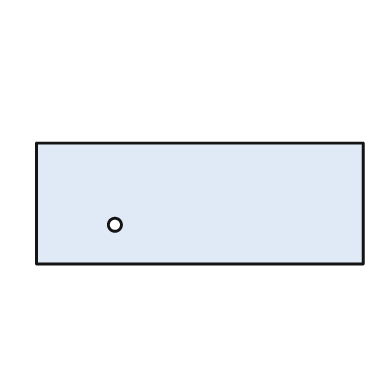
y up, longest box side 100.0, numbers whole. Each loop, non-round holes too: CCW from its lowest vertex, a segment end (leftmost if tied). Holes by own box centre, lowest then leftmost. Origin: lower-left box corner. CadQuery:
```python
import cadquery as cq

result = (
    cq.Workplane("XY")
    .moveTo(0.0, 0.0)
    .lineTo(100.0, 0.0)
    .lineTo(100.0, 37.0)
    .lineTo(0.0, 37.0)
    .close()
    .moveTo(24.0, 12.0)
    .circle(2.0)
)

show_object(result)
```